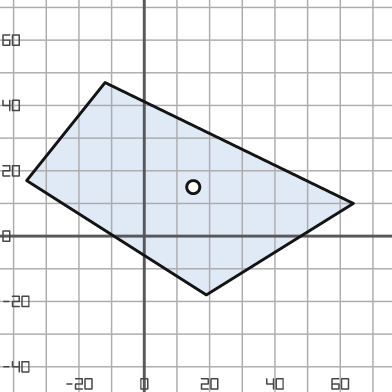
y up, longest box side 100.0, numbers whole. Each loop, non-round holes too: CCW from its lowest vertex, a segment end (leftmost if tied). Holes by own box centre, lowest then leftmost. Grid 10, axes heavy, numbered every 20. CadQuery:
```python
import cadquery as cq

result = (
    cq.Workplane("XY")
    .moveTo(19.0, -18.0)
    .lineTo(64.0, 10.0)
    .lineTo(-12.0, 47.0)
    .lineTo(-36.0, 17.0)
    .close()
    .moveTo(15.0, 15.0)
    .circle(2.0)
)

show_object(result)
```